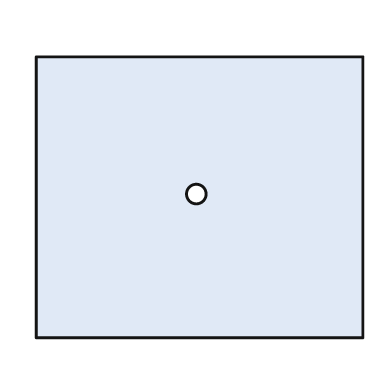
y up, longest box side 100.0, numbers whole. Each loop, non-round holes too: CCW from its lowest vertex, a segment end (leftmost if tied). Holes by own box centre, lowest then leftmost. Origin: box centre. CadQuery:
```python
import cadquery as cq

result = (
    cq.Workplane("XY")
    .moveTo(-50.0, -43.0)
    .lineTo(50.0, -43.0)
    .lineTo(50.0, 43.0)
    .lineTo(-50.0, 43.0)
    .close()
    .moveTo(-1.0, 1.0)
    .circle(3.0)
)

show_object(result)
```